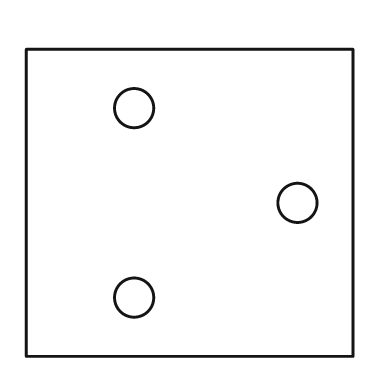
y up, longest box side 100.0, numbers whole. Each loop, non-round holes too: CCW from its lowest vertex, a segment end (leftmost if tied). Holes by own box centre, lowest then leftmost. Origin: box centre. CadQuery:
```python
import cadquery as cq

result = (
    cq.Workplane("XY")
    .moveTo(-50.0, -47.0)
    .lineTo(50.0, -47.0)
    .lineTo(50.0, 47.0)
    .lineTo(-50.0, 47.0)
    .close()
    .moveTo(-17.0, -29.0)
    .circle(6.0)
    .moveTo(33.0, 0.0)
    .circle(6.0)
    .moveTo(-17.0, 29.0)
    .circle(6.0)
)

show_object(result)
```